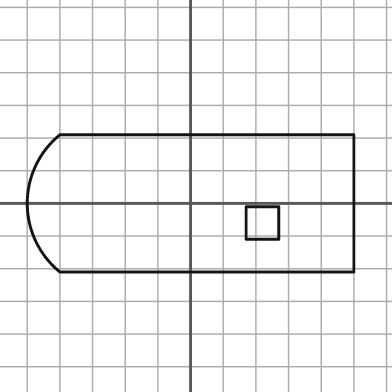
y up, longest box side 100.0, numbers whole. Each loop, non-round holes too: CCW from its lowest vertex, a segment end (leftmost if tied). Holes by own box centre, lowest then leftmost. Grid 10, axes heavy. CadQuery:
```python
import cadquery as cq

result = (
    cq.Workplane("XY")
    .moveTo(-40.0, -21.0)
    .lineTo(50.0, -21.0)
    .lineTo(50.0, 21.0)
    .lineTo(-40.0, 21.0)
    .threePointArc((-50.0, 0.0), (-40.0, -21.0))
    .close()
    .moveTo(17.0, -11.0)
    .lineTo(27.0, -11.0)
    .lineTo(27.0, -1.0)
    .lineTo(17.0, -1.0)
    .close()
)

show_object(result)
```